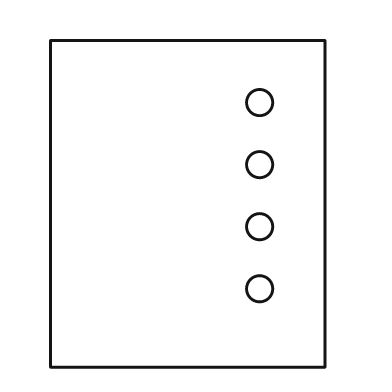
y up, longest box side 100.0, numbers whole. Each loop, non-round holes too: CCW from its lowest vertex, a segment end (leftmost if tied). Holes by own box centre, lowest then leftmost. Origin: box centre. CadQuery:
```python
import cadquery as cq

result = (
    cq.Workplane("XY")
    .moveTo(-42.0, -50.0)
    .lineTo(42.0, -50.0)
    .lineTo(42.0, 50.0)
    .lineTo(-42.0, 50.0)
    .close()
    .moveTo(22.0, -26.0)
    .circle(4.0)
    .moveTo(22.0, -7.0)
    .circle(4.0)
    .moveTo(22.0, 12.0)
    .circle(4.0)
    .moveTo(22.0, 31.0)
    .circle(4.0)
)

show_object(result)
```